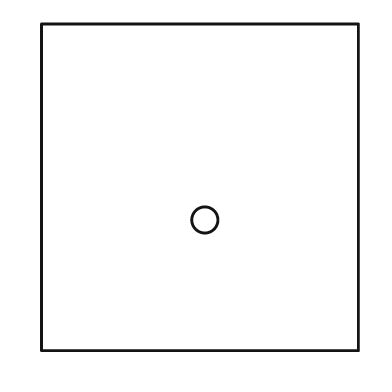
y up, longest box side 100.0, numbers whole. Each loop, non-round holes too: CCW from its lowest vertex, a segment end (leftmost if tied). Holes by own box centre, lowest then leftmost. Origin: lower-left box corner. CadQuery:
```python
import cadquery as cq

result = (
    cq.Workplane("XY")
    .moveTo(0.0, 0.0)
    .lineTo(97.0, 0.0)
    .lineTo(97.0, 100.0)
    .lineTo(0.0, 100.0)
    .close()
    .moveTo(50.0, 40.0)
    .circle(4.0)
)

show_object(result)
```